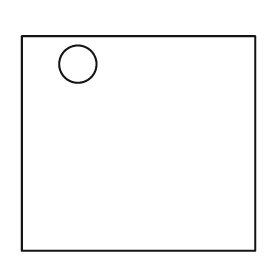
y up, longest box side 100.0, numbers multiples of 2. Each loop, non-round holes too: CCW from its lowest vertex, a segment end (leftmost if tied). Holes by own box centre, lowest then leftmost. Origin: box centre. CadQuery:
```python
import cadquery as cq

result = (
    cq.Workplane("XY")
    .moveTo(-50.0, -46.0)
    .lineTo(50.0, -46.0)
    .lineTo(50.0, 46.0)
    .lineTo(-50.0, 46.0)
    .close()
    .moveTo(-26.0, 34.0)
    .circle(8.0)
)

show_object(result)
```